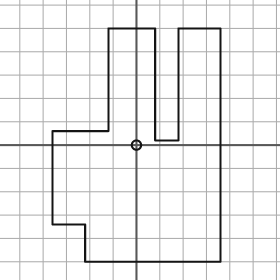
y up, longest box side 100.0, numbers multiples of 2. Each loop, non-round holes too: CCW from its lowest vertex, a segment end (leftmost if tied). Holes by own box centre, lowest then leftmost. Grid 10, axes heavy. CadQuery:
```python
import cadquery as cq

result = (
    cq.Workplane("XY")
    .moveTo(-22.0, -50.0)
    .lineTo(36.0, -50.0)
    .lineTo(36.0, 50.0)
    .lineTo(18.0, 50.0)
    .lineTo(18.0, 2.0)
    .lineTo(8.0, 2.0)
    .lineTo(8.0, 50.0)
    .lineTo(-12.0, 50.0)
    .lineTo(-12.0, 6.0)
    .lineTo(-36.0, 6.0)
    .lineTo(-36.0, -34.0)
    .lineTo(-22.0, -34.0)
    .close()
    .moveTo(0.0, 0.0)
    .circle(2.0)
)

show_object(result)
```